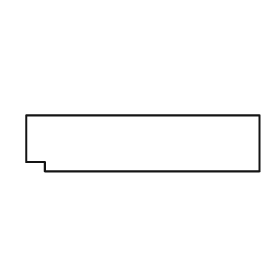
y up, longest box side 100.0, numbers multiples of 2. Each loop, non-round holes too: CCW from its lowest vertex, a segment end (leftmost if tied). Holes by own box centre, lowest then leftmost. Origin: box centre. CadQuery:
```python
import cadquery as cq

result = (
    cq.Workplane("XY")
    .moveTo(-42.0, -12.0)
    .lineTo(50.0, -12.0)
    .lineTo(50.0, 12.0)
    .lineTo(-50.0, 12.0)
    .lineTo(-50.0, -8.0)
    .lineTo(-42.0, -8.0)
    .close()
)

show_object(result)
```